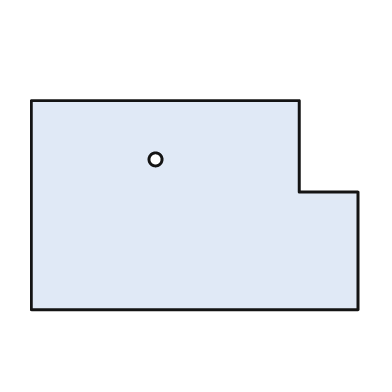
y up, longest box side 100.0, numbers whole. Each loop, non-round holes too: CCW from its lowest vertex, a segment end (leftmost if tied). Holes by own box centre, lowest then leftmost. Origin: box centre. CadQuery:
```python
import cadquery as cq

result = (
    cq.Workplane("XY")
    .moveTo(-50.0, -32.0)
    .lineTo(50.0, -32.0)
    .lineTo(50.0, 4.0)
    .lineTo(32.0, 4.0)
    .lineTo(32.0, 32.0)
    .lineTo(-50.0, 32.0)
    .close()
    .moveTo(-12.0, 14.0)
    .circle(2.0)
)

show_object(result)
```